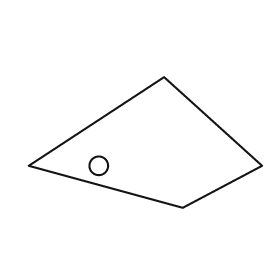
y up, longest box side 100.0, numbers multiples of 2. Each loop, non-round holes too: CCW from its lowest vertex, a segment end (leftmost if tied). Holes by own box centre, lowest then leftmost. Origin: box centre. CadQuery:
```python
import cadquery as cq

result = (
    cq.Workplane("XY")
    .moveTo(16.0, -28.0)
    .lineTo(50.0, -10.0)
    .lineTo(8.0, 28.0)
    .lineTo(-50.0, -10.0)
    .close()
    .moveTo(-20.0, -10.0)
    .circle(4.0)
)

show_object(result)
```